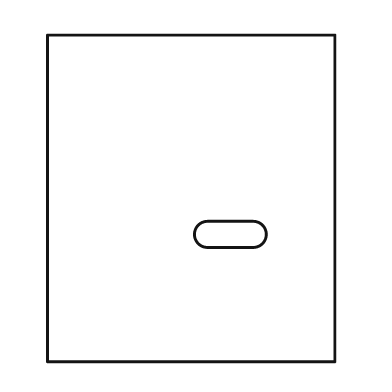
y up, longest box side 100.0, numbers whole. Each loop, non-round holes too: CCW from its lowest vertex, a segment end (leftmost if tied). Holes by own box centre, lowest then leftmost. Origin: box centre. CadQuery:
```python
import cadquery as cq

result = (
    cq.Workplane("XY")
    .moveTo(-44.0, -50.0)
    .lineTo(44.0, -50.0)
    .lineTo(44.0, 50.0)
    .lineTo(-44.0, 50.0)
    .close()
    .moveTo(5.0, -15.0)
    .lineTo(19.0, -15.0)
    .threePointArc((23.0, -11.0), (19.0, -7.0))
    .lineTo(5.0, -7.0)
    .threePointArc((1.0, -11.0), (5.0, -15.0))
    .close()
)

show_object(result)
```